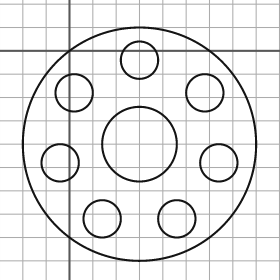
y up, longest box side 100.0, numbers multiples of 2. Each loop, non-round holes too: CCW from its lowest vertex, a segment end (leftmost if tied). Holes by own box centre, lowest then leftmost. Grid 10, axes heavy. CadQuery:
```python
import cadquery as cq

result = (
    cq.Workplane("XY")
    .moveTo(30.0, -40.0)
    .circle(50.0)
    .moveTo(14.0, -72.0)
    .circle(8.0)
    .moveTo(46.0, -72.0)
    .circle(8.0)
    .moveTo(-4.0, -48.0)
    .circle(8.0)
    .moveTo(64.0, -48.0)
    .circle(8.0)
    .moveTo(30.0, -40.0)
    .circle(16.0)
    .moveTo(2.0, -18.0)
    .circle(8.0)
    .moveTo(58.0, -18.0)
    .circle(8.0)
    .moveTo(30.0, -4.0)
    .circle(8.0)
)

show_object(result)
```